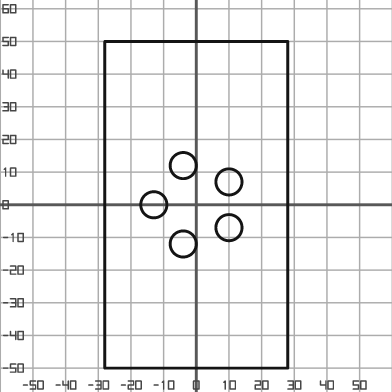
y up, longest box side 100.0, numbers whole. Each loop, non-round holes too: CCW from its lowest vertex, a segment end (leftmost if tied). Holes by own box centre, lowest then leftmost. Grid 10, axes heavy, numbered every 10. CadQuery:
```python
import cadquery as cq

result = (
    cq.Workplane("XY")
    .moveTo(-28.0, -50.0)
    .lineTo(28.0, -50.0)
    .lineTo(28.0, 50.0)
    .lineTo(-28.0, 50.0)
    .close()
    .moveTo(-4.0, -12.0)
    .circle(4.0)
    .moveTo(10.0, -7.0)
    .circle(4.0)
    .moveTo(-13.0, 0.0)
    .circle(4.0)
    .moveTo(10.0, 7.0)
    .circle(4.0)
    .moveTo(-4.0, 12.0)
    .circle(4.0)
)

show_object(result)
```